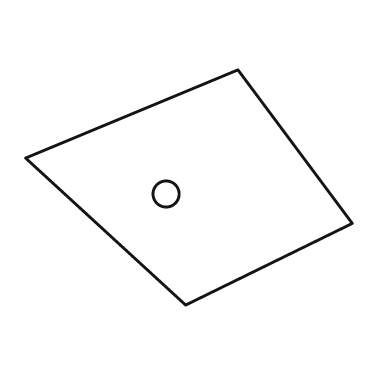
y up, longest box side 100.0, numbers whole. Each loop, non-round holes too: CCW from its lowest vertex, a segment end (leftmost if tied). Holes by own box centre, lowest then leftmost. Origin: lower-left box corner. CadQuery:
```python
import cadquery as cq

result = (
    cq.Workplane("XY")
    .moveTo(49.0, 0.0)
    .lineTo(100.0, 25.0)
    .lineTo(65.0, 72.0)
    .lineTo(0.0, 45.0)
    .close()
    .moveTo(43.0, 34.0)
    .circle(4.0)
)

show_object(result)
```